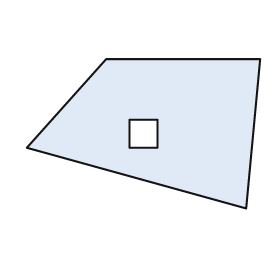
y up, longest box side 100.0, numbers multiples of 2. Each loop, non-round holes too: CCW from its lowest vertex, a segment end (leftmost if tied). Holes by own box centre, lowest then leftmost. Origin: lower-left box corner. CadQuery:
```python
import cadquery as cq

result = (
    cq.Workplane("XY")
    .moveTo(94.0, 0.0)
    .lineTo(100.0, 64.0)
    .lineTo(34.0, 64.0)
    .lineTo(0.0, 26.0)
    .close()
    .moveTo(44.0, 26.0)
    .lineTo(56.0, 26.0)
    .lineTo(56.0, 38.0)
    .lineTo(44.0, 38.0)
    .close()
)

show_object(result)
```